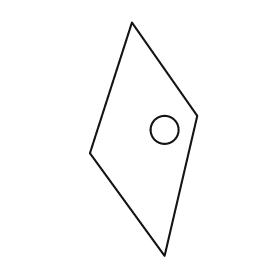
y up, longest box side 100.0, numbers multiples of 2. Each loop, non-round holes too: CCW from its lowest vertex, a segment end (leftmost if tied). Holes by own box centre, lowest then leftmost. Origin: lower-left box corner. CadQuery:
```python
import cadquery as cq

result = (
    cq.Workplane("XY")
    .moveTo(32.0, 0.0)
    .lineTo(46.0, 60.0)
    .lineTo(18.0, 100.0)
    .lineTo(0.0, 44.0)
    .close()
    .moveTo(32.0, 54.0)
    .circle(6.0)
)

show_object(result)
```